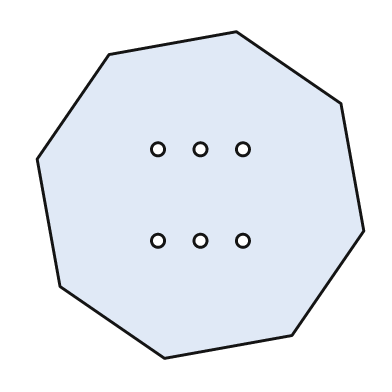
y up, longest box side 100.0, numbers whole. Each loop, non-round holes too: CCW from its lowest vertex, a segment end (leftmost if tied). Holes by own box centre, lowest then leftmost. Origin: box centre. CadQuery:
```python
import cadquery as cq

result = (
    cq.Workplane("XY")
    .moveTo(-11.0, -50.0)
    .lineTo(28.0, -43.0)
    .lineTo(50.0, -11.0)
    .lineTo(43.0, 28.0)
    .lineTo(11.0, 50.0)
    .lineTo(-28.0, 43.0)
    .lineTo(-50.0, 11.0)
    .lineTo(-43.0, -28.0)
    .close()
    .moveTo(-13.0, -14.0)
    .circle(2.0)
    .moveTo(0.0, -14.0)
    .circle(2.0)
    .moveTo(13.0, -14.0)
    .circle(2.0)
    .moveTo(-13.0, 14.0)
    .circle(2.0)
    .moveTo(0.0, 14.0)
    .circle(2.0)
    .moveTo(13.0, 14.0)
    .circle(2.0)
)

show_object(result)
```